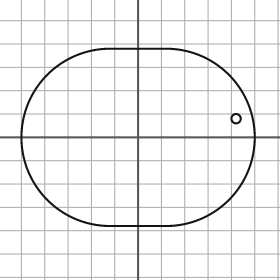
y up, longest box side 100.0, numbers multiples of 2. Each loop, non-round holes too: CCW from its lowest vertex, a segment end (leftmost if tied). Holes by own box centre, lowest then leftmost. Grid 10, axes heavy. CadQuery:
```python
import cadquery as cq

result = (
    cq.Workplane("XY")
    .moveTo(-12.0, -38.0)
    .lineTo(12.0, -38.0)
    .threePointArc((50.0, 0.0), (12.0, 38.0))
    .lineTo(-12.0, 38.0)
    .threePointArc((-50.0, 0.0), (-12.0, -38.0))
    .close()
    .moveTo(42.0, 8.0)
    .circle(2.0)
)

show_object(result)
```